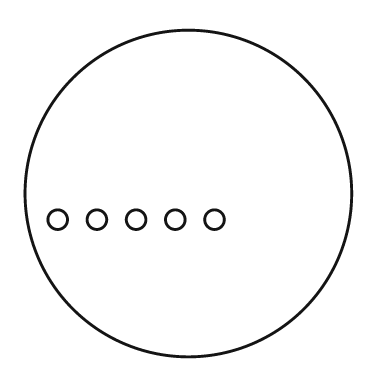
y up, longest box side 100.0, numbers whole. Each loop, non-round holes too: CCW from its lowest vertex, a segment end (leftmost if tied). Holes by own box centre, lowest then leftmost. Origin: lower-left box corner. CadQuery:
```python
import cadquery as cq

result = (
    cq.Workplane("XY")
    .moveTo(50.0, 50.0)
    .circle(50.0)
    .moveTo(10.0, 42.0)
    .circle(3.0)
    .moveTo(22.0, 42.0)
    .circle(3.0)
    .moveTo(34.0, 42.0)
    .circle(3.0)
    .moveTo(46.0, 42.0)
    .circle(3.0)
    .moveTo(58.0, 42.0)
    .circle(3.0)
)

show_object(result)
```